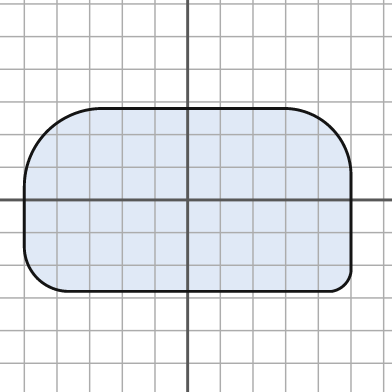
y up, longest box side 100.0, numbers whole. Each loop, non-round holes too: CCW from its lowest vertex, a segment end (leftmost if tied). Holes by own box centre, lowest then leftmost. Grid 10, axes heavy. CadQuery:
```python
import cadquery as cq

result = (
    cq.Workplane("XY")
    .moveTo(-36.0, -28.0)
    .lineTo(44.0, -28.0)
    .threePointArc((48.0, -26.0), (50.0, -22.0))
    .lineTo(50.0, 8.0)
    .threePointArc((44.0, 22.0), (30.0, 28.0))
    .lineTo(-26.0, 28.0)
    .threePointArc((-43.0, 21.0), (-50.0, 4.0))
    .lineTo(-50.0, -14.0)
    .threePointArc((-46.0, -24.0), (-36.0, -28.0))
    .close()
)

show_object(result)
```